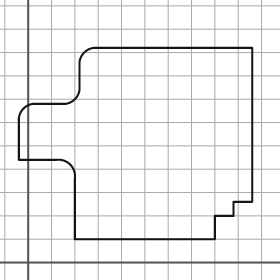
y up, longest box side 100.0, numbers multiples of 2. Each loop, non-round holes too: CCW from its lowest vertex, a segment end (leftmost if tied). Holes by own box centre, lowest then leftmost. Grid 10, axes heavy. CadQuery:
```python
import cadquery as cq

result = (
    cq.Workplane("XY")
    .moveTo(20.0, 10.0)
    .lineTo(80.0, 10.0)
    .lineTo(80.0, 20.0)
    .lineTo(88.0, 20.0)
    .lineTo(88.0, 26.0)
    .lineTo(96.0, 26.0)
    .lineTo(96.0, 92.0)
    .lineTo(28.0, 92.0)
    .threePointArc((24.0, 90.0), (22.0, 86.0))
    .lineTo(22.0, 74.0)
    .threePointArc((20.0, 70.0), (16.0, 68.0))
    .lineTo(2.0, 68.0)
    .threePointArc((-2.0, 66.0), (-4.0, 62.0))
    .lineTo(-4.0, 44.0)
    .lineTo(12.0, 44.0)
    .threePointArc((18.0, 42.0), (20.0, 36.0))
    .close()
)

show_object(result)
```